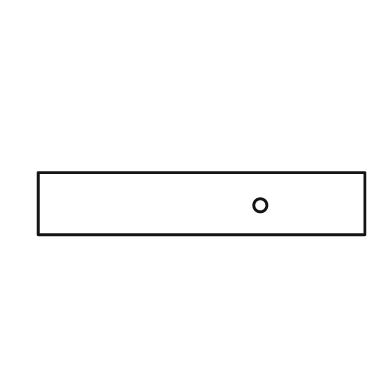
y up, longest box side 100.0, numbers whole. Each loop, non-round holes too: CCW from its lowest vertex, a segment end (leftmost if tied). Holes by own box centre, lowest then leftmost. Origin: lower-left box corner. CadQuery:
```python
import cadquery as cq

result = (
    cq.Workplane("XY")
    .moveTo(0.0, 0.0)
    .lineTo(100.0, 0.0)
    .lineTo(100.0, 19.0)
    .lineTo(0.0, 19.0)
    .close()
    .moveTo(68.0, 9.0)
    .circle(2.0)
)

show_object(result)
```